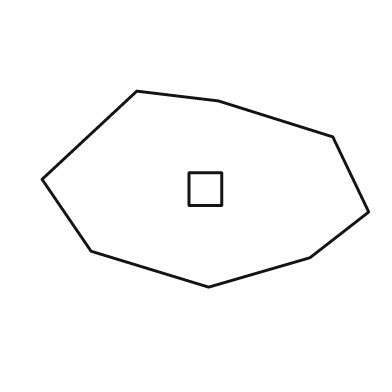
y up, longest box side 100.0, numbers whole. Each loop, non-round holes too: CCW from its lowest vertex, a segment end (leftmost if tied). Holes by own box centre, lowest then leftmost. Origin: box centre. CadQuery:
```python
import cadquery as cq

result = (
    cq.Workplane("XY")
    .moveTo(1.0, -30.0)
    .lineTo(32.0, -21.0)
    .lineTo(50.0, -7.0)
    .lineTo(39.0, 16.0)
    .lineTo(4.0, 27.0)
    .lineTo(-21.0, 30.0)
    .lineTo(-50.0, 3.0)
    .lineTo(-35.0, -19.0)
    .close()
    .moveTo(-5.0, -5.0)
    .lineTo(5.0, -5.0)
    .lineTo(5.0, 5.0)
    .lineTo(-5.0, 5.0)
    .close()
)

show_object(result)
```